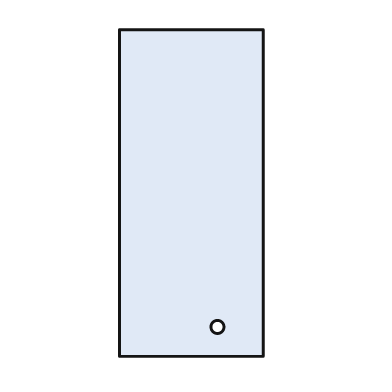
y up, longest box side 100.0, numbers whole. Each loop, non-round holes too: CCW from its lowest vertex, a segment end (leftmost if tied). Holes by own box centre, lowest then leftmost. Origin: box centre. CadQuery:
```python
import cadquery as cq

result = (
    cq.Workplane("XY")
    .moveTo(-22.0, -50.0)
    .lineTo(22.0, -50.0)
    .lineTo(22.0, 50.0)
    .lineTo(-22.0, 50.0)
    .close()
    .moveTo(8.0, -41.0)
    .circle(2.0)
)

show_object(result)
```